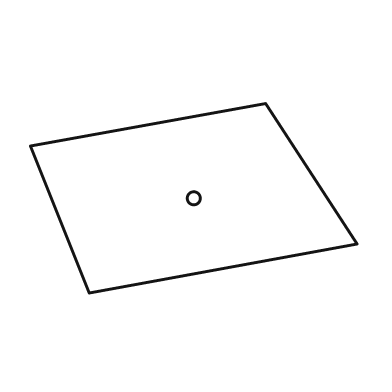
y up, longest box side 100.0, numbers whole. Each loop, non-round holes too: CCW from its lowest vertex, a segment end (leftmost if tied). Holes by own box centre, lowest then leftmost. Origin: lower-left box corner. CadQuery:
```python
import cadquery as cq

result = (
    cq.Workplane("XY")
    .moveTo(18.0, 0.0)
    .lineTo(100.0, 15.0)
    .lineTo(72.0, 58.0)
    .lineTo(0.0, 45.0)
    .close()
    .moveTo(50.0, 29.0)
    .circle(2.0)
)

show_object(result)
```